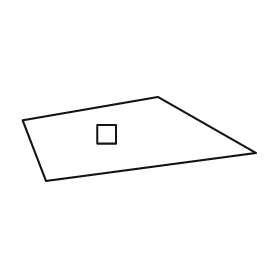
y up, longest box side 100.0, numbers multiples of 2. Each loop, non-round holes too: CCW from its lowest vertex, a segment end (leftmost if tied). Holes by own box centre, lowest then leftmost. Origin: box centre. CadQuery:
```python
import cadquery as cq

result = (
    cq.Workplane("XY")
    .moveTo(-40.0, -18.0)
    .lineTo(50.0, -6.0)
    .lineTo(8.0, 18.0)
    .lineTo(-50.0, 8.0)
    .close()
    .moveTo(-18.0, -2.0)
    .lineTo(-10.0, -2.0)
    .lineTo(-10.0, 6.0)
    .lineTo(-18.0, 6.0)
    .close()
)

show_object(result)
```